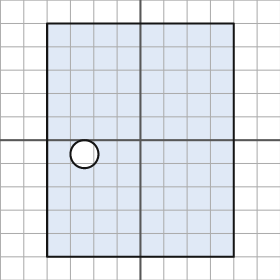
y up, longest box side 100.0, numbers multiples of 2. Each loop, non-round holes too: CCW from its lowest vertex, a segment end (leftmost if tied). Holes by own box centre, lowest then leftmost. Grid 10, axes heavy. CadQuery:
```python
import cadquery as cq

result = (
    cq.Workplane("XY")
    .moveTo(-40.0, -50.0)
    .lineTo(40.0, -50.0)
    .lineTo(40.0, 50.0)
    .lineTo(-40.0, 50.0)
    .close()
    .moveTo(-24.0, -6.0)
    .circle(6.0)
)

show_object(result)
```